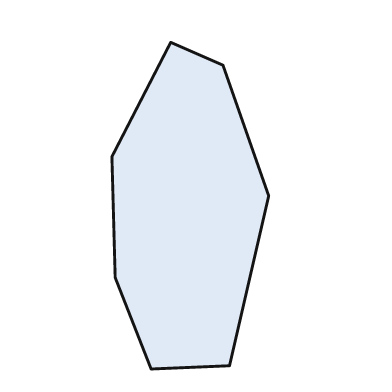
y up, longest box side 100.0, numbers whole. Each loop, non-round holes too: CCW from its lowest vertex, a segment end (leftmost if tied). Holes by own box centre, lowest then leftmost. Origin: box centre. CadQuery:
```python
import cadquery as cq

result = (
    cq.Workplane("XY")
    .moveTo(-12.0, -50.0)
    .lineTo(12.0, -49.0)
    .lineTo(24.0, 3.0)
    .lineTo(10.0, 43.0)
    .lineTo(-6.0, 50.0)
    .lineTo(-24.0, 15.0)
    .lineTo(-23.0, -22.0)
    .close()
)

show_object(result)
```